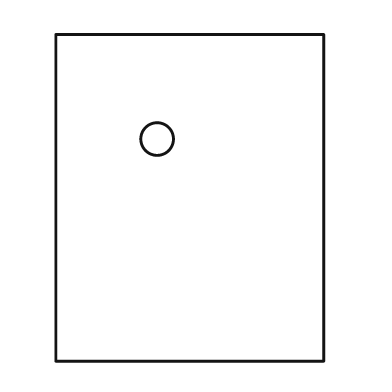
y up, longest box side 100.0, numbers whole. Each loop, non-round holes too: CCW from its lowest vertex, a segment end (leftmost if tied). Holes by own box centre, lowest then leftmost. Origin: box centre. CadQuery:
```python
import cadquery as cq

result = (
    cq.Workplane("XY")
    .moveTo(-41.0, -50.0)
    .lineTo(41.0, -50.0)
    .lineTo(41.0, 50.0)
    .lineTo(-41.0, 50.0)
    .close()
    .moveTo(-10.0, 18.0)
    .circle(5.0)
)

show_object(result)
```